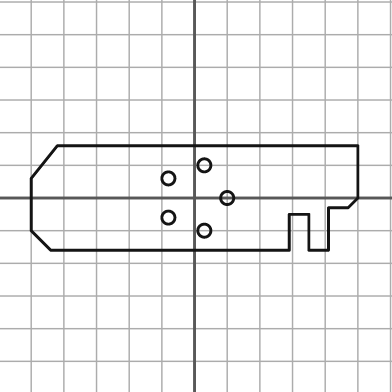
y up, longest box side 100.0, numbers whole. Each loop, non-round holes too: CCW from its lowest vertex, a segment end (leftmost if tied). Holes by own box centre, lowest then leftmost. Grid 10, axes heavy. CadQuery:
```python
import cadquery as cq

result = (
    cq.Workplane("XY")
    .moveTo(-44.0, -16.0)
    .lineTo(29.0, -16.0)
    .lineTo(29.0, -5.0)
    .lineTo(35.0, -5.0)
    .lineTo(35.0, -16.0)
    .lineTo(41.0, -16.0)
    .lineTo(41.0, -3.0)
    .lineTo(47.0, -3.0)
    .lineTo(50.0, 0.0)
    .lineTo(50.0, 16.0)
    .lineTo(-42.0, 16.0)
    .lineTo(-50.0, 6.0)
    .lineTo(-50.0, -10.0)
    .close()
    .moveTo(3.0, -10.0)
    .circle(2.0)
    .moveTo(-8.0, -6.0)
    .circle(2.0)
    .moveTo(10.0, 0.0)
    .circle(2.0)
    .moveTo(-8.0, 6.0)
    .circle(2.0)
    .moveTo(3.0, 10.0)
    .circle(2.0)
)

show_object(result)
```